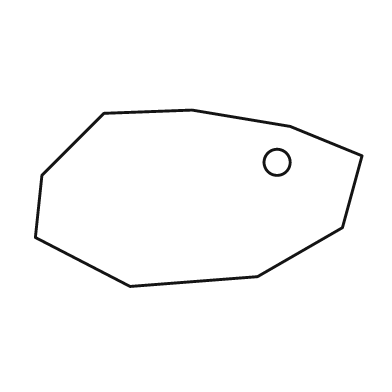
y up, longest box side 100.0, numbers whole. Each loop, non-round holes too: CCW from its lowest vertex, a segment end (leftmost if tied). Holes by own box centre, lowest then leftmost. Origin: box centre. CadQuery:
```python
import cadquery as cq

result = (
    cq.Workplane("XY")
    .moveTo(-21.0, -27.0)
    .lineTo(18.0, -24.0)
    .lineTo(44.0, -9.0)
    .lineTo(50.0, 13.0)
    .lineTo(28.0, 22.0)
    .lineTo(-2.0, 27.0)
    .lineTo(-29.0, 26.0)
    .lineTo(-48.0, 7.0)
    .lineTo(-50.0, -12.0)
    .close()
    .moveTo(24.0, 11.0)
    .circle(4.0)
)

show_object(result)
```